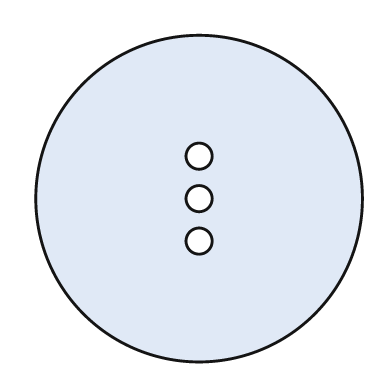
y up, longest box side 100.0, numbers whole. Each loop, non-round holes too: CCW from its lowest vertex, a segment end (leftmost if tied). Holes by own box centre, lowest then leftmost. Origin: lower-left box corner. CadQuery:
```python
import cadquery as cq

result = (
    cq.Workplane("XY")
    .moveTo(50.0, 50.0)
    .circle(50.0)
    .moveTo(50.0, 37.0)
    .circle(4.0)
    .moveTo(50.0, 50.0)
    .circle(4.0)
    .moveTo(50.0, 63.0)
    .circle(4.0)
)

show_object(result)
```